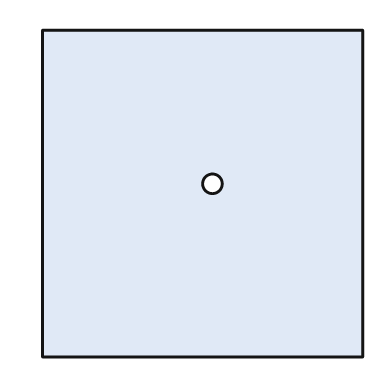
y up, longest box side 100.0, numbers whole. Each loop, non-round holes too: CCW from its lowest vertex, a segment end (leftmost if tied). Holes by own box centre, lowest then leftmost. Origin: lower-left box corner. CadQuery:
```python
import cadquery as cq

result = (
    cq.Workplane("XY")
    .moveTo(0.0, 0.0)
    .lineTo(98.0, 0.0)
    .lineTo(98.0, 100.0)
    .lineTo(0.0, 100.0)
    .close()
    .moveTo(52.0, 53.0)
    .circle(3.0)
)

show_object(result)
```